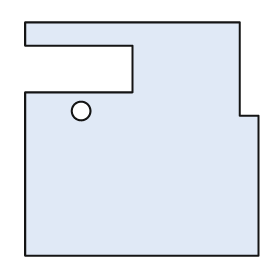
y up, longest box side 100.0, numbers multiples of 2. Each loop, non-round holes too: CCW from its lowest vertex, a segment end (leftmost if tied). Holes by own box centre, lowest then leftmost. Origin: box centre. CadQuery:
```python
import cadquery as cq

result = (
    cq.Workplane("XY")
    .moveTo(-50.0, -50.0)
    .lineTo(50.0, -50.0)
    .lineTo(50.0, 10.0)
    .lineTo(42.0, 10.0)
    .lineTo(42.0, 50.0)
    .lineTo(-50.0, 50.0)
    .lineTo(-50.0, 40.0)
    .lineTo(-4.0, 40.0)
    .lineTo(-4.0, 20.0)
    .lineTo(-50.0, 20.0)
    .close()
    .moveTo(-26.0, 12.0)
    .circle(4.0)
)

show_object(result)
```